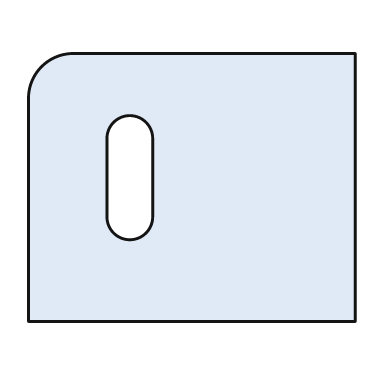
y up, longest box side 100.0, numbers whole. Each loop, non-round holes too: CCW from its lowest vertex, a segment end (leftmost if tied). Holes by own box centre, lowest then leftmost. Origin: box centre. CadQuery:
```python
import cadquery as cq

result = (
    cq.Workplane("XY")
    .moveTo(-50.0, -41.0)
    .lineTo(50.0, -41.0)
    .lineTo(50.0, 41.0)
    .lineTo(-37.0, 41.0)
    .threePointArc((-46.0, 37.0), (-50.0, 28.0))
    .close()
    .moveTo(-26.0, -9.0)
    .threePointArc((-19.0, -16.0), (-12.0, -9.0))
    .lineTo(-12.0, 15.0)
    .threePointArc((-19.0, 22.0), (-26.0, 15.0))
    .close()
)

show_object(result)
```